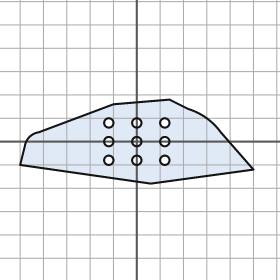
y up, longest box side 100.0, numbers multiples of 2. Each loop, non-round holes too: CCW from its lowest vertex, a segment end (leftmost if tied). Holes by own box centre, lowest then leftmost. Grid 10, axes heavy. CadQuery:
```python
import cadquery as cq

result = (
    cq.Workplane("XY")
    .moveTo(6.0, -18.0)
    .lineTo(50.0, -12.0)
    .lineTo(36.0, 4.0)
    .threePointArc((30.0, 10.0), (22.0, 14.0))
    .lineTo(14.0, 18.0)
    .lineTo(-10.0, 16.0)
    .lineTo(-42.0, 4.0)
    .threePointArc((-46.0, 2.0), (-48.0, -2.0))
    .lineTo(-50.0, -10.0)
    .close()
    .moveTo(-12.0, -8.0)
    .circle(2.0)
    .moveTo(0.0, -8.0)
    .circle(2.0)
    .moveTo(12.0, -8.0)
    .circle(2.0)
    .moveTo(-12.0, 0.0)
    .circle(2.0)
    .moveTo(0.0, 0.0)
    .circle(2.0)
    .moveTo(12.0, 0.0)
    .circle(2.0)
    .moveTo(-12.0, 8.0)
    .circle(2.0)
    .moveTo(0.0, 8.0)
    .circle(2.0)
    .moveTo(12.0, 8.0)
    .circle(2.0)
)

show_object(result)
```